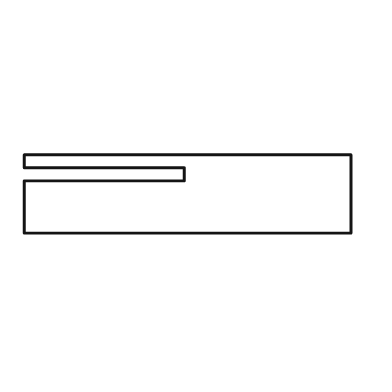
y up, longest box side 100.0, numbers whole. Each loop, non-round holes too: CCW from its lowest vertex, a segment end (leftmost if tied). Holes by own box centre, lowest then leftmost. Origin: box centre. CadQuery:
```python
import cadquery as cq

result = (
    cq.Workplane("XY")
    .moveTo(-50.0, -12.0)
    .lineTo(50.0, -12.0)
    .lineTo(50.0, 12.0)
    .lineTo(-50.0, 12.0)
    .lineTo(-50.0, 8.0)
    .lineTo(-1.0, 8.0)
    .lineTo(-1.0, 4.0)
    .lineTo(-50.0, 4.0)
    .close()
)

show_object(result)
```